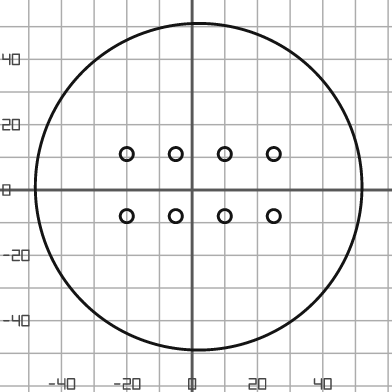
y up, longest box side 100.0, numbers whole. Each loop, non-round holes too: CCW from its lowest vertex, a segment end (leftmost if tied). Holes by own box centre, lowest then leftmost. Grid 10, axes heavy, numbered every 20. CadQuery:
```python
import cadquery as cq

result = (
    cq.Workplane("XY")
    .moveTo(2.0, 1.0)
    .circle(50.0)
    .moveTo(-20.0, -8.0)
    .circle(2.0)
    .moveTo(-5.0, -8.0)
    .circle(2.0)
    .moveTo(10.0, -8.0)
    .circle(2.0)
    .moveTo(25.0, -8.0)
    .circle(2.0)
    .moveTo(-20.0, 11.0)
    .circle(2.0)
    .moveTo(-5.0, 11.0)
    .circle(2.0)
    .moveTo(10.0, 11.0)
    .circle(2.0)
    .moveTo(25.0, 11.0)
    .circle(2.0)
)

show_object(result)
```